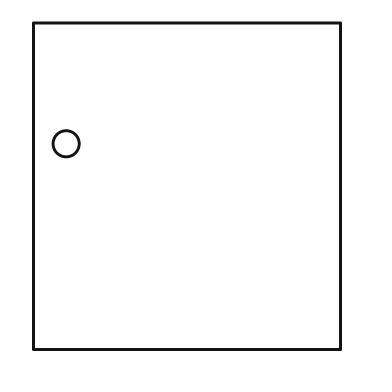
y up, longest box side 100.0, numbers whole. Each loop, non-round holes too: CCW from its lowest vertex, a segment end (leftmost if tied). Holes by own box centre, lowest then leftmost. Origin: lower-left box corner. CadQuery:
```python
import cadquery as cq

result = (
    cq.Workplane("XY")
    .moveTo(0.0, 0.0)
    .lineTo(94.0, 0.0)
    .lineTo(94.0, 100.0)
    .lineTo(0.0, 100.0)
    .close()
    .moveTo(10.0, 63.0)
    .circle(4.0)
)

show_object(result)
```